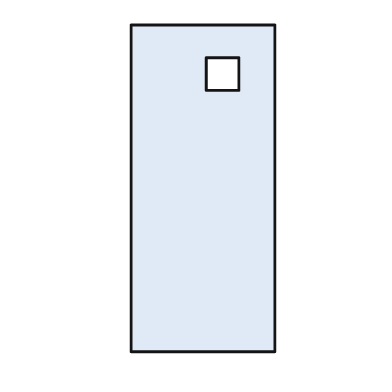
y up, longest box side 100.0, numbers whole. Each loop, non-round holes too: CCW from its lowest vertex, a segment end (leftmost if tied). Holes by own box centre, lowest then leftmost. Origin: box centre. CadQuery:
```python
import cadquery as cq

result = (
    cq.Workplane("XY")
    .moveTo(-22.0, -50.0)
    .lineTo(22.0, -50.0)
    .lineTo(22.0, 50.0)
    .lineTo(-22.0, 50.0)
    .close()
    .moveTo(1.0, 30.0)
    .lineTo(11.0, 30.0)
    .lineTo(11.0, 40.0)
    .lineTo(1.0, 40.0)
    .close()
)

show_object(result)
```